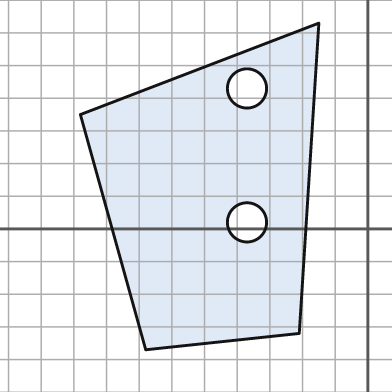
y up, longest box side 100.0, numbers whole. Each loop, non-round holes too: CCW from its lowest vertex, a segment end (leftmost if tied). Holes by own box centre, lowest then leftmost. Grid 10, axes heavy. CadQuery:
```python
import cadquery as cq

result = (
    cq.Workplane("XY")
    .moveTo(-68.0, -37.0)
    .lineTo(-21.0, -32.0)
    .lineTo(-15.0, 63.0)
    .lineTo(-88.0, 35.0)
    .close()
    .moveTo(-37.0, 2.0)
    .circle(6.0)
    .moveTo(-37.0, 43.0)
    .circle(6.0)
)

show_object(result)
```